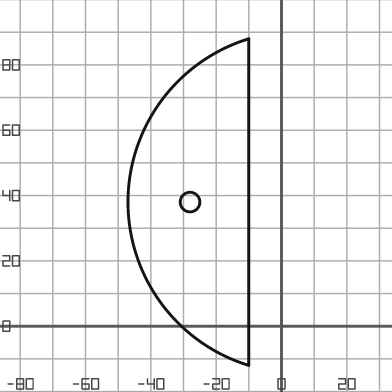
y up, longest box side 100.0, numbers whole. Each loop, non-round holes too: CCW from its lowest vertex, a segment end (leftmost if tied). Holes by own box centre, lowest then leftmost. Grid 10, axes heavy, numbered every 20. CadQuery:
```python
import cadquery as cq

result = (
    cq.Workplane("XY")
    .moveTo(-10.0, -12.0)
    .lineTo(-10.0, 88.0)
    .threePointArc((-47.0, 38.0), (-10.0, -12.0))
    .close()
    .moveTo(-28.0, 38.0)
    .circle(3.0)
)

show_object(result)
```